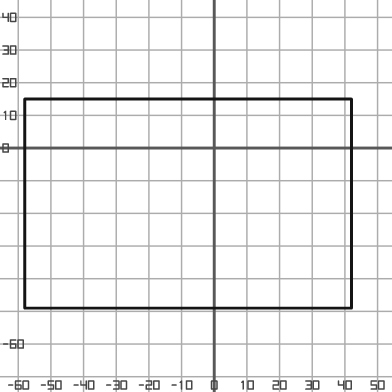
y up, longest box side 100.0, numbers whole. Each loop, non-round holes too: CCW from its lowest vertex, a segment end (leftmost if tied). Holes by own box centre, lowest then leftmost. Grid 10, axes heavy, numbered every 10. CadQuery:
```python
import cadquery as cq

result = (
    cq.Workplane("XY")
    .moveTo(-58.0, -49.0)
    .lineTo(42.0, -49.0)
    .lineTo(42.0, 15.0)
    .lineTo(-58.0, 15.0)
    .close()
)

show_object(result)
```